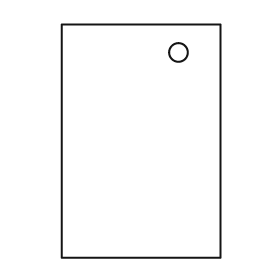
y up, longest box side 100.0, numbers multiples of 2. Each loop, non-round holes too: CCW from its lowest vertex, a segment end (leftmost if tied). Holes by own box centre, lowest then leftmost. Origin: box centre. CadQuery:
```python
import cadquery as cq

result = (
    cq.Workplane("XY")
    .moveTo(-34.0, -50.0)
    .lineTo(34.0, -50.0)
    .lineTo(34.0, 50.0)
    .lineTo(-34.0, 50.0)
    .close()
    .moveTo(16.0, 38.0)
    .circle(4.0)
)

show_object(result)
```